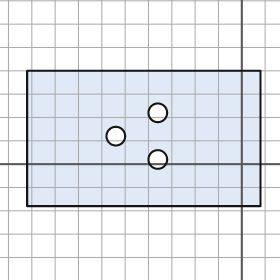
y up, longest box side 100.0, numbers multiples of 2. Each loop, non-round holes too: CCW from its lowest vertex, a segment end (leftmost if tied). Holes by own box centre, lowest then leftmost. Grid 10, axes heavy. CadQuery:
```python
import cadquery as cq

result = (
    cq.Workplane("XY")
    .moveTo(-92.0, -18.0)
    .lineTo(8.0, -18.0)
    .lineTo(8.0, 40.0)
    .lineTo(-92.0, 40.0)
    .close()
    .moveTo(-36.0, 2.0)
    .circle(4.0)
    .moveTo(-54.0, 12.0)
    .circle(4.0)
    .moveTo(-36.0, 22.0)
    .circle(4.0)
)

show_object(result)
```